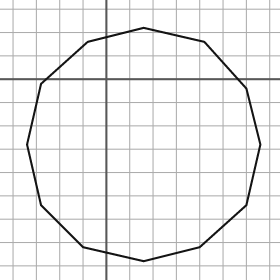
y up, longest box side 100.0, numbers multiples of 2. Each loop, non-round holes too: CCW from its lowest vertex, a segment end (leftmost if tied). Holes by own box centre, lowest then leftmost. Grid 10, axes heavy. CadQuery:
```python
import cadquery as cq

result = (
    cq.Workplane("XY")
    .moveTo(16.0, -78.0)
    .lineTo(40.0, -72.0)
    .lineTo(60.0, -54.0)
    .lineTo(66.0, -28.0)
    .lineTo(60.0, -4.0)
    .lineTo(42.0, 16.0)
    .lineTo(16.0, 22.0)
    .lineTo(-8.0, 16.0)
    .lineTo(-28.0, -2.0)
    .lineTo(-34.0, -28.0)
    .lineTo(-28.0, -54.0)
    .lineTo(-10.0, -72.0)
    .close()
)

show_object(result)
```